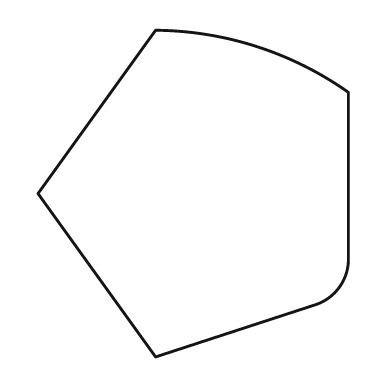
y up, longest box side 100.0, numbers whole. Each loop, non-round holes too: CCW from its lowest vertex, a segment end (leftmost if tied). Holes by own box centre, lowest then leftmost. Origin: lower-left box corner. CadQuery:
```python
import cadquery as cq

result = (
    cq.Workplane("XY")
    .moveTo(36.0, 0.0)
    .lineTo(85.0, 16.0)
    .threePointArc((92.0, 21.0), (95.0, 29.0))
    .lineTo(95.0, 81.0)
    .threePointArc((67.0, 95.0), (36.0, 100.0))
    .lineTo(0.0, 50.0)
    .close()
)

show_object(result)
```